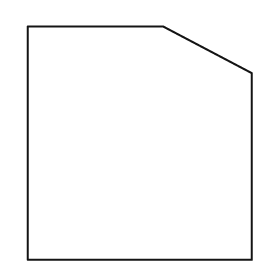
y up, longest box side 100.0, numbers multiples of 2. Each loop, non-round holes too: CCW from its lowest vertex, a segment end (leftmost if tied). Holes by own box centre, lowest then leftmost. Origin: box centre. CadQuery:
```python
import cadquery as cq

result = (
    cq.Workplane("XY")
    .moveTo(-48.0, -50.0)
    .lineTo(48.0, -50.0)
    .lineTo(48.0, 30.0)
    .lineTo(10.0, 50.0)
    .lineTo(-48.0, 50.0)
    .close()
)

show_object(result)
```